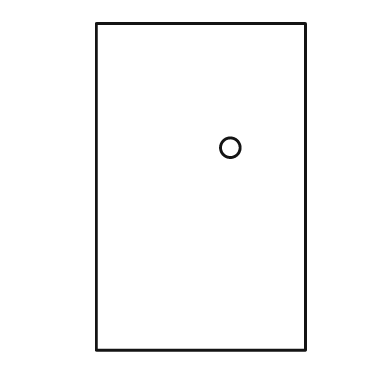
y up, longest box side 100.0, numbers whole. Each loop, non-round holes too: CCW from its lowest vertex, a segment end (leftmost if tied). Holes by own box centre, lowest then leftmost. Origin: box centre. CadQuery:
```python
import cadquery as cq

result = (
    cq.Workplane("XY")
    .moveTo(-32.0, -50.0)
    .lineTo(32.0, -50.0)
    .lineTo(32.0, 50.0)
    .lineTo(-32.0, 50.0)
    .close()
    .moveTo(9.0, 12.0)
    .circle(3.0)
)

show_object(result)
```